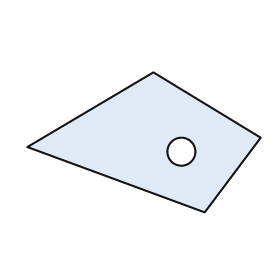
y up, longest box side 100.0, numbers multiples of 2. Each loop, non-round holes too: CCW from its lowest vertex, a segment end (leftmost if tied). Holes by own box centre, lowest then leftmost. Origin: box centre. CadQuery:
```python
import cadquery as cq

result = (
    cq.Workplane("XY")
    .moveTo(26.0, -30.0)
    .lineTo(50.0, 2.0)
    .lineTo(4.0, 30.0)
    .lineTo(-50.0, -2.0)
    .close()
    .moveTo(16.0, -4.0)
    .circle(6.0)
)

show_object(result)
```